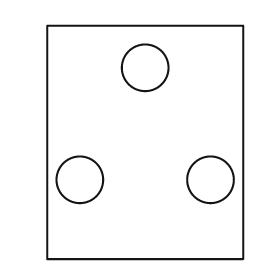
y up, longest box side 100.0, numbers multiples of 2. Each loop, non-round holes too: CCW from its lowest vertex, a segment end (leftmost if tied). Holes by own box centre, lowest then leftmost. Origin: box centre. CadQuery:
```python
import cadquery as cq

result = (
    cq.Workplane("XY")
    .moveTo(-42.0, -50.0)
    .lineTo(42.0, -50.0)
    .lineTo(42.0, 50.0)
    .lineTo(-42.0, 50.0)
    .close()
    .moveTo(-28.0, -16.0)
    .circle(10.0)
    .moveTo(28.0, -16.0)
    .circle(10.0)
    .moveTo(0.0, 32.0)
    .circle(10.0)
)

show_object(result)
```